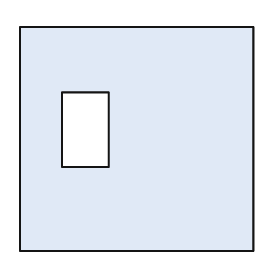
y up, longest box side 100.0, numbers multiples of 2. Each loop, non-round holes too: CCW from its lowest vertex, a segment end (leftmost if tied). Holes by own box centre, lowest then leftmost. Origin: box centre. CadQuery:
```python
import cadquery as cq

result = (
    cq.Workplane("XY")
    .moveTo(-50.0, -48.0)
    .lineTo(50.0, -48.0)
    .lineTo(50.0, 48.0)
    .lineTo(-50.0, 48.0)
    .close()
    .moveTo(-32.0, -12.0)
    .lineTo(-12.0, -12.0)
    .lineTo(-12.0, 20.0)
    .lineTo(-32.0, 20.0)
    .close()
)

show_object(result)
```